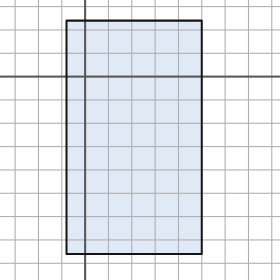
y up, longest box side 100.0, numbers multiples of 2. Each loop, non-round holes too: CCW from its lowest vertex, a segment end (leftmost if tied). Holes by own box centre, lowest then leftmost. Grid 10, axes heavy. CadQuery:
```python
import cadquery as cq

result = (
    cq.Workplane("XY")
    .moveTo(-8.0, -76.0)
    .lineTo(50.0, -76.0)
    .lineTo(50.0, 24.0)
    .lineTo(-8.0, 24.0)
    .close()
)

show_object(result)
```